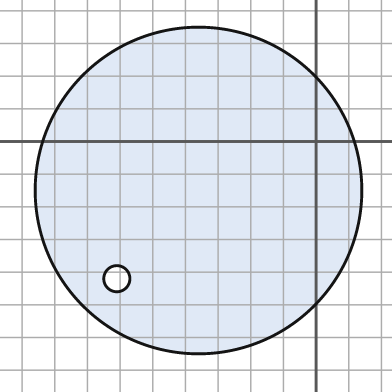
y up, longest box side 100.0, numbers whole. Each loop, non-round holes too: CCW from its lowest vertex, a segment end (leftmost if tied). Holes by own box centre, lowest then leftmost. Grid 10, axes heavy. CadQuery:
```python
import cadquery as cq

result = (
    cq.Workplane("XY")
    .moveTo(-36.0, -15.0)
    .circle(50.0)
    .moveTo(-61.0, -42.0)
    .circle(4.0)
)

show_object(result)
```